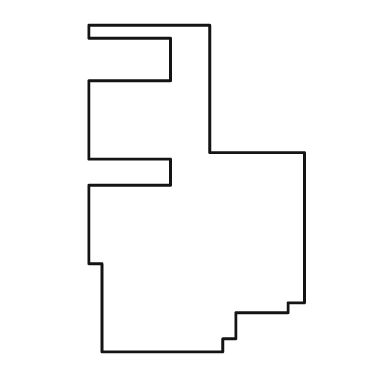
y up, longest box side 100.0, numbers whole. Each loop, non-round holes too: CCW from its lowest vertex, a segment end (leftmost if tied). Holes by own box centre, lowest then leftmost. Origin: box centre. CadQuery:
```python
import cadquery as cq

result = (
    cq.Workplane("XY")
    .moveTo(-29.0, -50.0)
    .lineTo(8.0, -50.0)
    .lineTo(8.0, -46.0)
    .lineTo(12.0, -46.0)
    .lineTo(12.0, -38.0)
    .lineTo(28.0, -38.0)
    .lineTo(28.0, -35.0)
    .lineTo(33.0, -35.0)
    .lineTo(33.0, 11.0)
    .lineTo(4.0, 11.0)
    .lineTo(4.0, 50.0)
    .lineTo(-33.0, 50.0)
    .lineTo(-33.0, 46.0)
    .lineTo(-8.0, 46.0)
    .lineTo(-8.0, 33.0)
    .lineTo(-33.0, 33.0)
    .lineTo(-33.0, 9.0)
    .lineTo(-8.0, 9.0)
    .lineTo(-8.0, 1.0)
    .lineTo(-33.0, 1.0)
    .lineTo(-33.0, -23.0)
    .lineTo(-29.0, -23.0)
    .close()
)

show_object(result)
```